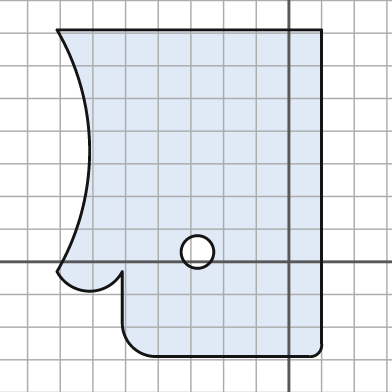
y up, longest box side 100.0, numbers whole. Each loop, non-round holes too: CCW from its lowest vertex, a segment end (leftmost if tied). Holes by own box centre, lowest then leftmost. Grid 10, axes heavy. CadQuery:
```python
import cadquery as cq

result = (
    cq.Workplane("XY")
    .moveTo(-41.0, -29.0)
    .lineTo(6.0, -29.0)
    .threePointArc((9.0, -28.0), (10.0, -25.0))
    .lineTo(10.0, 71.0)
    .lineTo(-71.0, 71.0)
    .threePointArc((-61.0, 34.0), (-71.0, -3.0))
    .threePointArc((-61.0, -9.0), (-51.0, -3.0))
    .lineTo(-51.0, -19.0)
    .threePointArc((-48.0, -26.0), (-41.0, -29.0))
    .close()
    .moveTo(-28.0, 3.0)
    .circle(5.0)
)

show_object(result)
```